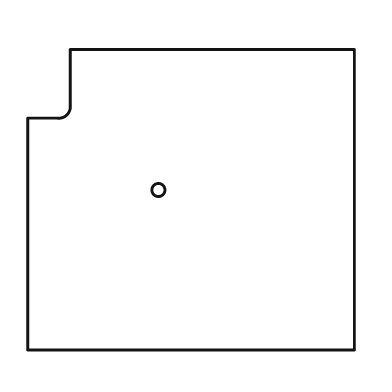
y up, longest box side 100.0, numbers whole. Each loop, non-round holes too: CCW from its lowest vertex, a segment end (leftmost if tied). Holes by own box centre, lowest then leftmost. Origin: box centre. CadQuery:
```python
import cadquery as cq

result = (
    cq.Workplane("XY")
    .moveTo(-50.0, -46.0)
    .lineTo(50.0, -46.0)
    .lineTo(50.0, 46.0)
    .lineTo(-37.0, 46.0)
    .lineTo(-37.0, 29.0)
    .threePointArc((-38.0, 26.0), (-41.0, 25.0))
    .lineTo(-50.0, 25.0)
    .close()
    .moveTo(-10.0, 3.0)
    .circle(2.0)
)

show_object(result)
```